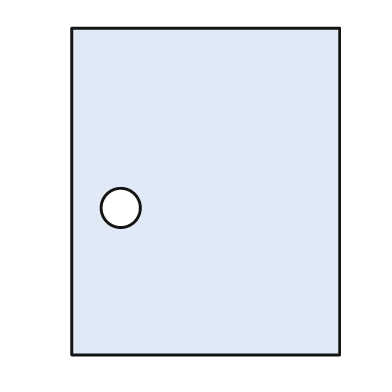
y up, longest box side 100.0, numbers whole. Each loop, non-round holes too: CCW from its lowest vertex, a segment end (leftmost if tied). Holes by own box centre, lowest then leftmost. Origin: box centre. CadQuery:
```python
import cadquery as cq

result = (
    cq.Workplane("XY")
    .moveTo(-41.0, -50.0)
    .lineTo(41.0, -50.0)
    .lineTo(41.0, 50.0)
    .lineTo(-41.0, 50.0)
    .close()
    .moveTo(-26.0, -5.0)
    .circle(6.0)
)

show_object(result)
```